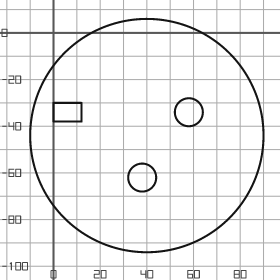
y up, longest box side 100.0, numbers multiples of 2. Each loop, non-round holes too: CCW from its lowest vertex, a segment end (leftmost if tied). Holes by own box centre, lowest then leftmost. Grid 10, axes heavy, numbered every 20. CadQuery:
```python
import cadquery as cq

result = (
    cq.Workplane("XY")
    .moveTo(40.0, -44.0)
    .circle(50.0)
    .moveTo(38.0, -62.0)
    .circle(6.0)
    .moveTo(0.0, -38.0)
    .lineTo(12.0, -38.0)
    .lineTo(12.0, -30.0)
    .lineTo(0.0, -30.0)
    .close()
    .moveTo(58.0, -34.0)
    .circle(6.0)
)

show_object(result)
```